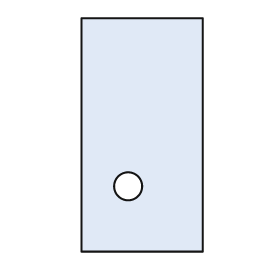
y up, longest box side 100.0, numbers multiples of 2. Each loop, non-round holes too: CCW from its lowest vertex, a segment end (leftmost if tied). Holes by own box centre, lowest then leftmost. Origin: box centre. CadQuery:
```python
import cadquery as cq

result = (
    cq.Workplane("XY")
    .moveTo(-26.0, -50.0)
    .lineTo(26.0, -50.0)
    .lineTo(26.0, 50.0)
    .lineTo(-26.0, 50.0)
    .close()
    .moveTo(-6.0, -22.0)
    .circle(6.0)
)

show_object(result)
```